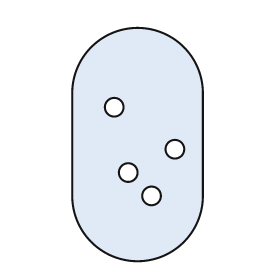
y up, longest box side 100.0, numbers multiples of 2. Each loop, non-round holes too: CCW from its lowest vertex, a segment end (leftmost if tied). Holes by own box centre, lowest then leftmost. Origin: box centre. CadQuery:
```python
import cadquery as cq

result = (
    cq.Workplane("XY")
    .moveTo(-28.0, -22.0)
    .threePointArc((0.0, -50.0), (28.0, -22.0))
    .lineTo(28.0, 22.0)
    .threePointArc((0.0, 50.0), (-28.0, 22.0))
    .close()
    .moveTo(6.0, -22.0)
    .circle(4.0)
    .moveTo(-4.0, -12.0)
    .circle(4.0)
    .moveTo(16.0, -2.0)
    .circle(4.0)
    .moveTo(-10.0, 16.0)
    .circle(4.0)
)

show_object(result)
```